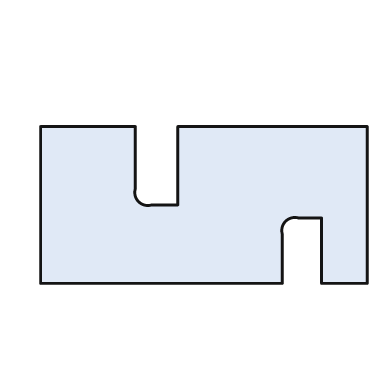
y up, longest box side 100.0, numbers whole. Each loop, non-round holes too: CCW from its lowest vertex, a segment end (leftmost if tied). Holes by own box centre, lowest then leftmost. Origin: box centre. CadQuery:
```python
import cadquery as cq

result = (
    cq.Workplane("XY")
    .moveTo(-50.0, -24.0)
    .lineTo(24.0, -24.0)
    .lineTo(24.0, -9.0)
    .threePointArc((25.0, -5.0), (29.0, -4.0))
    .lineTo(36.0, -4.0)
    .lineTo(36.0, -24.0)
    .lineTo(50.0, -24.0)
    .lineTo(50.0, 24.0)
    .lineTo(-8.0, 24.0)
    .lineTo(-8.0, 0.0)
    .lineTo(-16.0, 0.0)
    .threePointArc((-20.0, 1.0), (-21.0, 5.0))
    .lineTo(-21.0, 24.0)
    .lineTo(-50.0, 24.0)
    .close()
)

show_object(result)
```